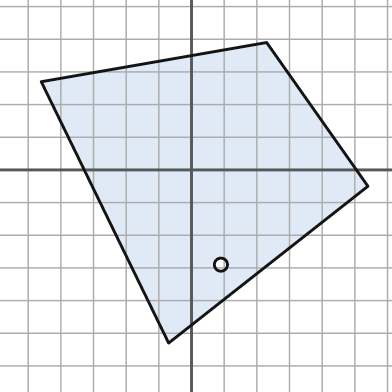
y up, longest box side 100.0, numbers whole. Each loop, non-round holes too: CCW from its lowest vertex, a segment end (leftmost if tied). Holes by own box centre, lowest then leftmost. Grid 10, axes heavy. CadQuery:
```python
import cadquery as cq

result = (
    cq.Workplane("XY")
    .moveTo(-7.0, -53.0)
    .lineTo(54.0, -5.0)
    .lineTo(23.0, 39.0)
    .lineTo(-46.0, 27.0)
    .close()
    .moveTo(9.0, -29.0)
    .circle(2.0)
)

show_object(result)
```